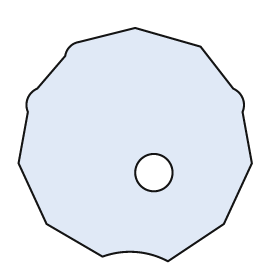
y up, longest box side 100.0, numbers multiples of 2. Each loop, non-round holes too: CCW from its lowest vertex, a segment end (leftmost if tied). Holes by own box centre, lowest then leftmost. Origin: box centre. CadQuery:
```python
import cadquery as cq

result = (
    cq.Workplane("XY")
    .moveTo(14.0, -50.0)
    .lineTo(38.0, -34.0)
    .lineTo(50.0, -8.0)
    .lineTo(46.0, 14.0)
    .threePointArc((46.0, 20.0), (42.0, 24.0))
    .lineTo(28.0, 42.0)
    .lineTo(0.0, 50.0)
    .lineTo(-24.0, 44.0)
    .threePointArc((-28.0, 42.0), (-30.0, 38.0))
    .lineTo(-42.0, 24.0)
    .threePointArc((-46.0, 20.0), (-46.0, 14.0))
    .lineTo(-50.0, -8.0)
    .lineTo(-38.0, -34.0)
    .lineTo(-14.0, -48.0)
    .threePointArc((0.0, -46.0), (14.0, -50.0))
    .close()
    .moveTo(8.0, -12.0)
    .circle(8.0)
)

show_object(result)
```